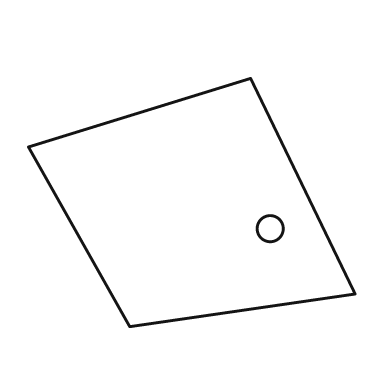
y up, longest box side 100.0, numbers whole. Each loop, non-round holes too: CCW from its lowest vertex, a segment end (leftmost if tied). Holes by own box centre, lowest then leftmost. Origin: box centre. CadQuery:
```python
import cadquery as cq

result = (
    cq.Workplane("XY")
    .moveTo(-19.0, -38.0)
    .lineTo(50.0, -28.0)
    .lineTo(18.0, 38.0)
    .lineTo(-50.0, 17.0)
    .close()
    .moveTo(24.0, -8.0)
    .circle(4.0)
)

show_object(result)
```